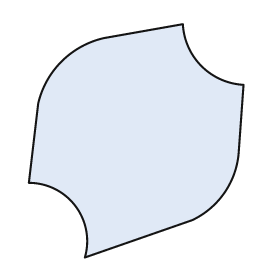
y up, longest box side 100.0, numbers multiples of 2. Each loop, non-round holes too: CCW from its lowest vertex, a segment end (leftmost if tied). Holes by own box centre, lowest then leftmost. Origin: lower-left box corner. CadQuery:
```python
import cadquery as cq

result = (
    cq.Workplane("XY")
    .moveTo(24.0, 0.0)
    .lineTo(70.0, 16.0)
    .threePointArc((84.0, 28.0), (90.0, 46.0))
    .lineTo(92.0, 74.0)
    .threePointArc((74.0, 82.0), (66.0, 100.0))
    .lineTo(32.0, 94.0)
    .threePointArc((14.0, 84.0), (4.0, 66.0))
    .lineTo(0.0, 32.0)
    .threePointArc((20.0, 22.0), (24.0, 0.0))
    .close()
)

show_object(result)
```